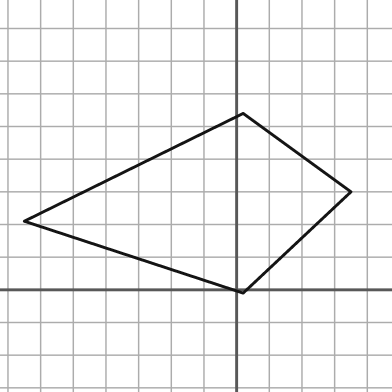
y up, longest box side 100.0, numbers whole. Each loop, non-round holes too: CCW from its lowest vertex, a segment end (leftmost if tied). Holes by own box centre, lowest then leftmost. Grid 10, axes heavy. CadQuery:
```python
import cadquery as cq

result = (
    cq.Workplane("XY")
    .moveTo(2.0, -1.0)
    .lineTo(35.0, 30.0)
    .lineTo(2.0, 54.0)
    .lineTo(-65.0, 21.0)
    .close()
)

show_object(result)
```